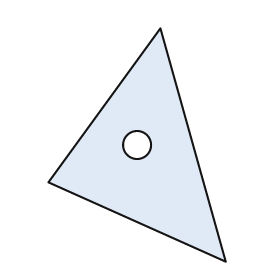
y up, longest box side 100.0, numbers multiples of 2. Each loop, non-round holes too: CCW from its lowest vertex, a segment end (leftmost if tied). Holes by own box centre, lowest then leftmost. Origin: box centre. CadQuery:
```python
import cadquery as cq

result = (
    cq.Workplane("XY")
    .moveTo(38.0, -50.0)
    .lineTo(10.0, 50.0)
    .lineTo(-38.0, -16.0)
    .close()
    .moveTo(0.0, 0.0)
    .circle(6.0)
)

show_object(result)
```